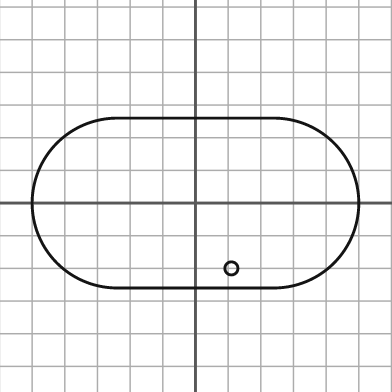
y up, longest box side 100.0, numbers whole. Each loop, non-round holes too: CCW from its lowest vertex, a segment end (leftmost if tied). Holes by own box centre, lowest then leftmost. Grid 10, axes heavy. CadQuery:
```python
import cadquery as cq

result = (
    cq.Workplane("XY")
    .moveTo(-24.0, -26.0)
    .lineTo(24.0, -26.0)
    .threePointArc((50.0, 0.0), (24.0, 26.0))
    .lineTo(-24.0, 26.0)
    .threePointArc((-50.0, 0.0), (-24.0, -26.0))
    .close()
    .moveTo(11.0, -20.0)
    .circle(2.0)
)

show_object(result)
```